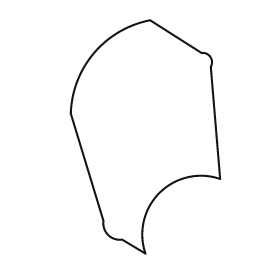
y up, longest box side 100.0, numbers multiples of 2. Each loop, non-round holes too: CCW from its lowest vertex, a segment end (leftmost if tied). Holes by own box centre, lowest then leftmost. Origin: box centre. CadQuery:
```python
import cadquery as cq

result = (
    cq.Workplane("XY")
    .moveTo(0.0, -50.0)
    .threePointArc((6.0, -24.0), (32.0, -18.0))
    .lineTo(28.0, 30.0)
    .threePointArc((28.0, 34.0), (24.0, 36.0))
    .lineTo(2.0, 50.0)
    .threePointArc((-22.0, 36.0), (-32.0, 10.0))
    .lineTo(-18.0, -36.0)
    .threePointArc((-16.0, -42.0), (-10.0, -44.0))
    .close()
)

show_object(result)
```